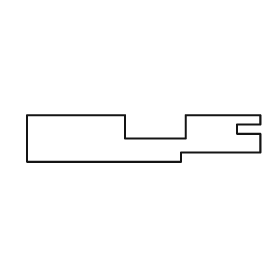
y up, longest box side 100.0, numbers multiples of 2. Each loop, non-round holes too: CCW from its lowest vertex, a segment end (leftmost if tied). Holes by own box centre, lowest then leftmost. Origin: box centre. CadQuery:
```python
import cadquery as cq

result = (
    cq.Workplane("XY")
    .moveTo(-50.0, -10.0)
    .lineTo(16.0, -10.0)
    .lineTo(16.0, -6.0)
    .lineTo(50.0, -6.0)
    .lineTo(50.0, 2.0)
    .lineTo(40.0, 2.0)
    .lineTo(40.0, 6.0)
    .lineTo(50.0, 6.0)
    .lineTo(50.0, 10.0)
    .lineTo(18.0, 10.0)
    .lineTo(18.0, 0.0)
    .lineTo(-8.0, 0.0)
    .lineTo(-8.0, 10.0)
    .lineTo(-50.0, 10.0)
    .close()
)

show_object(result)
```